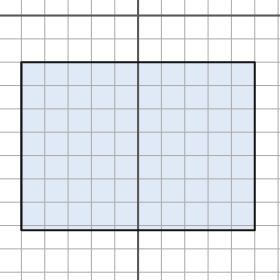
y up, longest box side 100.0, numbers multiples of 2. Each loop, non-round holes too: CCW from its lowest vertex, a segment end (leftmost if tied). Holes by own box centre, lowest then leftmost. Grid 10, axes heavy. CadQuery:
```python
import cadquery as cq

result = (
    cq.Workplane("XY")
    .moveTo(-50.0, -92.0)
    .lineTo(50.0, -92.0)
    .lineTo(50.0, -20.0)
    .lineTo(-50.0, -20.0)
    .close()
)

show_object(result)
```